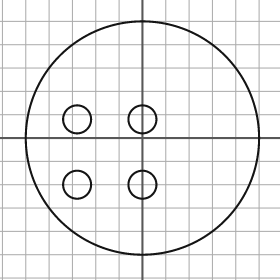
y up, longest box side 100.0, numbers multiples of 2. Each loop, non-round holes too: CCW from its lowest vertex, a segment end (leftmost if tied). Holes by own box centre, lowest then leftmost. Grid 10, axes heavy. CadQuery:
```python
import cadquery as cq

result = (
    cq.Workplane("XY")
    .moveTo(0.0, 0.0)
    .circle(50.0)
    .moveTo(-28.0, -20.0)
    .circle(6.0)
    .moveTo(0.0, -20.0)
    .circle(6.0)
    .moveTo(-28.0, 8.0)
    .circle(6.0)
    .moveTo(0.0, 8.0)
    .circle(6.0)
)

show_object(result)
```